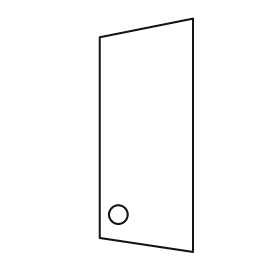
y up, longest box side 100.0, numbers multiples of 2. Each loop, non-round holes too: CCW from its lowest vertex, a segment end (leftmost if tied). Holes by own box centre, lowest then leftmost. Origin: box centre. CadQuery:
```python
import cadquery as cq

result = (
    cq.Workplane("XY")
    .moveTo(20.0, -50.0)
    .lineTo(20.0, 50.0)
    .lineTo(-20.0, 42.0)
    .lineTo(-20.0, -44.0)
    .close()
    .moveTo(-12.0, -34.0)
    .circle(4.0)
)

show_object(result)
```